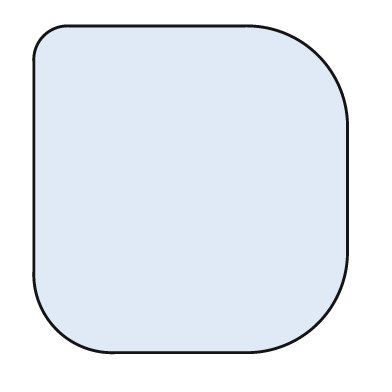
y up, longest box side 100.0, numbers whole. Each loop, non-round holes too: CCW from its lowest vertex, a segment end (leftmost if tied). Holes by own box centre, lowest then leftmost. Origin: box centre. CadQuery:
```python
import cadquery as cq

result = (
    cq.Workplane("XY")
    .moveTo(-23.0, -50.0)
    .lineTo(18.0, -50.0)
    .threePointArc((39.0, -41.0), (48.0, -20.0))
    .lineTo(48.0, 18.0)
    .threePointArc((39.0, 41.0), (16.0, 50.0))
    .lineTo(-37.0, 50.0)
    .threePointArc((-45.0, 47.0), (-48.0, 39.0))
    .lineTo(-48.0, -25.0)
    .threePointArc((-41.0, -43.0), (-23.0, -50.0))
    .close()
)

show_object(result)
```